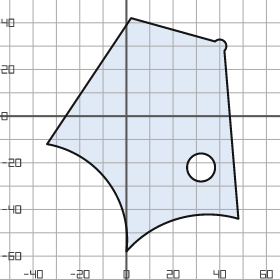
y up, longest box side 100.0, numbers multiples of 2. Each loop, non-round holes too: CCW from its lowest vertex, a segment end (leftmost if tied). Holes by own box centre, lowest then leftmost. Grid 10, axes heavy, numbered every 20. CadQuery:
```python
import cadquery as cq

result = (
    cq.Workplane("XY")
    .moveTo(0.0, -58.0)
    .threePointArc((22.0, -44.0), (48.0, -44.0))
    .lineTo(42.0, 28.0)
    .threePointArc((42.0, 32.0), (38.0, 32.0))
    .lineTo(2.0, 42.0)
    .lineTo(-34.0, -12.0)
    .threePointArc((-8.0, -28.0), (0.0, -58.0))
    .close()
    .moveTo(32.0, -22.0)
    .circle(6.0)
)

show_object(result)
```